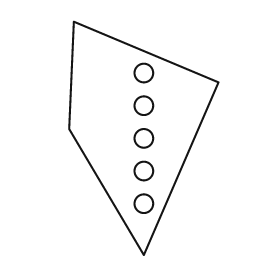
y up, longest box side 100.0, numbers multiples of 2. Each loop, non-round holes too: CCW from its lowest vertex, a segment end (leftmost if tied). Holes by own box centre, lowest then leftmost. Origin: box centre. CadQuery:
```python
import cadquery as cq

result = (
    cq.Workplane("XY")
    .moveTo(0.0, -50.0)
    .lineTo(32.0, 24.0)
    .lineTo(-30.0, 50.0)
    .lineTo(-32.0, 4.0)
    .close()
    .moveTo(0.0, -28.0)
    .circle(4.0)
    .moveTo(0.0, -14.0)
    .circle(4.0)
    .moveTo(0.0, 0.0)
    .circle(4.0)
    .moveTo(0.0, 14.0)
    .circle(4.0)
    .moveTo(0.0, 28.0)
    .circle(4.0)
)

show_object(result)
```